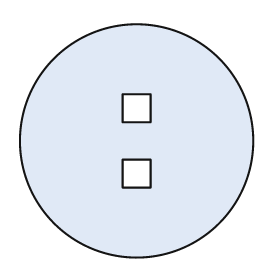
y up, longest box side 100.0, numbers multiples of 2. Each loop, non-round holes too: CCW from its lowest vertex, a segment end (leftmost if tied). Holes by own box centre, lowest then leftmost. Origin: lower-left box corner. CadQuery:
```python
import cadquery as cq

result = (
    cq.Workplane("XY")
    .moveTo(50.0, 50.0)
    .circle(50.0)
    .moveTo(44.0, 30.0)
    .lineTo(56.0, 30.0)
    .lineTo(56.0, 42.0)
    .lineTo(44.0, 42.0)
    .close()
    .moveTo(44.0, 58.0)
    .lineTo(56.0, 58.0)
    .lineTo(56.0, 70.0)
    .lineTo(44.0, 70.0)
    .close()
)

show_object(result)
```